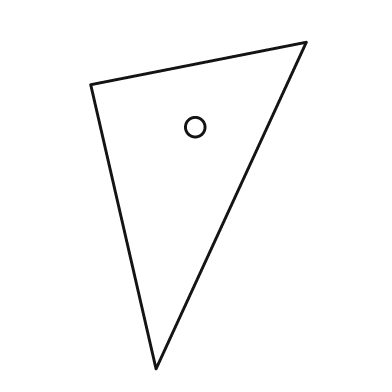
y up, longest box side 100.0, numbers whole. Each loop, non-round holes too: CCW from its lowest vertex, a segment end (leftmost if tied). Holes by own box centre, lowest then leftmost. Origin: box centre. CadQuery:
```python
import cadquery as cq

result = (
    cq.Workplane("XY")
    .moveTo(-13.0, -50.0)
    .lineTo(33.0, 50.0)
    .lineTo(-33.0, 37.0)
    .close()
    .moveTo(-1.0, 24.0)
    .circle(3.0)
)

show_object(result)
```